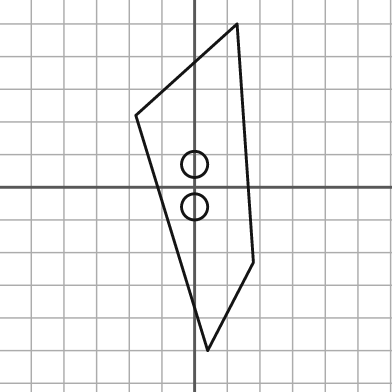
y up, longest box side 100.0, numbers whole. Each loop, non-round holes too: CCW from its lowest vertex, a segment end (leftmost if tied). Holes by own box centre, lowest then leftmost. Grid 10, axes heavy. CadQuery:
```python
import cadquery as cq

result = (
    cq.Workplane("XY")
    .moveTo(4.0, -50.0)
    .lineTo(18.0, -23.0)
    .lineTo(13.0, 50.0)
    .lineTo(-18.0, 22.0)
    .close()
    .moveTo(0.0, -6.0)
    .circle(4.0)
    .moveTo(0.0, 7.0)
    .circle(4.0)
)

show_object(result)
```